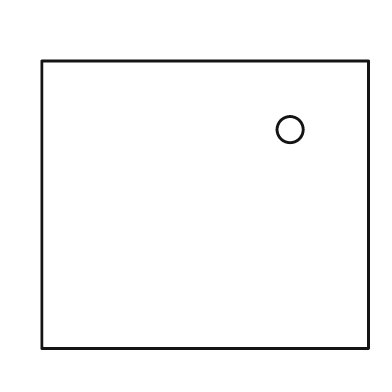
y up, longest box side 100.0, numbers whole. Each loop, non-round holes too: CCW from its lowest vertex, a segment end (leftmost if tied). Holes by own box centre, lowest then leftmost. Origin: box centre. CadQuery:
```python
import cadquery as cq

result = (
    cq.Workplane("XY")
    .moveTo(-50.0, -44.0)
    .lineTo(50.0, -44.0)
    .lineTo(50.0, 44.0)
    .lineTo(-50.0, 44.0)
    .close()
    .moveTo(26.0, 23.0)
    .circle(4.0)
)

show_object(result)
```